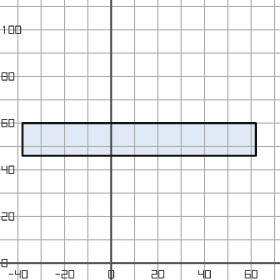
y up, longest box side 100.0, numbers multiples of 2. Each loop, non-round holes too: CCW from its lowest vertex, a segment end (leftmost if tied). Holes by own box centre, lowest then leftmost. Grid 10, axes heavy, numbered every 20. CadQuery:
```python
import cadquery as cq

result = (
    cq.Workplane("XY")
    .moveTo(-38.0, 46.0)
    .lineTo(62.0, 46.0)
    .lineTo(62.0, 60.0)
    .lineTo(-38.0, 60.0)
    .close()
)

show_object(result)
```